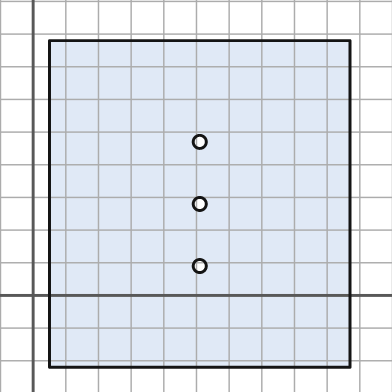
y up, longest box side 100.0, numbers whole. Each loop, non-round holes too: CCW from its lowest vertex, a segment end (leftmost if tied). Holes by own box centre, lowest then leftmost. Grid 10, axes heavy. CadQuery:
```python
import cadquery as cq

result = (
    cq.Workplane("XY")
    .moveTo(5.0, -22.0)
    .lineTo(97.0, -22.0)
    .lineTo(97.0, 78.0)
    .lineTo(5.0, 78.0)
    .close()
    .moveTo(51.0, 9.0)
    .circle(2.0)
    .moveTo(51.0, 28.0)
    .circle(2.0)
    .moveTo(51.0, 47.0)
    .circle(2.0)
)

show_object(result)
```